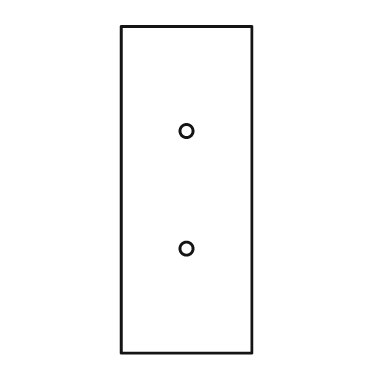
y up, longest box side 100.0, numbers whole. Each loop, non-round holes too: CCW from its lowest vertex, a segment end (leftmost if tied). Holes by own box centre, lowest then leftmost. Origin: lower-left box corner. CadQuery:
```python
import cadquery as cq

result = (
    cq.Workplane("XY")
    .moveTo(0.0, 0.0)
    .lineTo(40.0, 0.0)
    .lineTo(40.0, 100.0)
    .lineTo(0.0, 100.0)
    .close()
    .moveTo(20.0, 32.0)
    .circle(2.0)
    .moveTo(20.0, 68.0)
    .circle(2.0)
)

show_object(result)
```